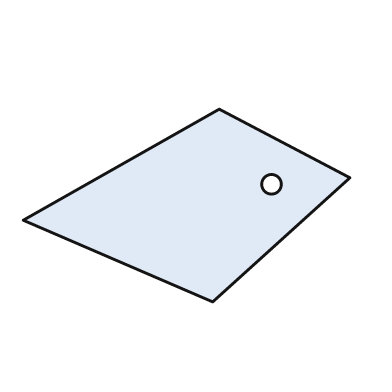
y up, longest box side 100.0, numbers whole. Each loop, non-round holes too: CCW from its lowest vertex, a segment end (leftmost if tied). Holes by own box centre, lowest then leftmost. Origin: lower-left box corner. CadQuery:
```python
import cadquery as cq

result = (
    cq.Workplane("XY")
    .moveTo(58.0, 0.0)
    .lineTo(100.0, 38.0)
    .lineTo(60.0, 59.0)
    .lineTo(0.0, 25.0)
    .close()
    .moveTo(76.0, 36.0)
    .circle(3.0)
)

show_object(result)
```